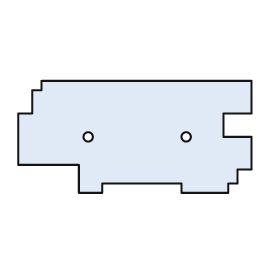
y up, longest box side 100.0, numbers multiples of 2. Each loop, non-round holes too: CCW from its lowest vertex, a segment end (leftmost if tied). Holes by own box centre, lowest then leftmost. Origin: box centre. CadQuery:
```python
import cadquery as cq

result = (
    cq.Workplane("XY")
    .moveTo(-24.0, -24.0)
    .lineTo(-14.0, -24.0)
    .lineTo(-14.0, -20.0)
    .lineTo(20.0, -20.0)
    .lineTo(20.0, -24.0)
    .lineTo(40.0, -24.0)
    .lineTo(40.0, -20.0)
    .lineTo(44.0, -20.0)
    .lineTo(44.0, -14.0)
    .lineTo(50.0, -14.0)
    .lineTo(50.0, 0.0)
    .lineTo(38.0, 0.0)
    .lineTo(38.0, 10.0)
    .lineTo(50.0, 10.0)
    .lineTo(50.0, 24.0)
    .lineTo(-40.0, 24.0)
    .lineTo(-40.0, 20.0)
    .lineTo(-44.0, 20.0)
    .lineTo(-44.0, 10.0)
    .lineTo(-50.0, 10.0)
    .lineTo(-50.0, -12.0)
    .lineTo(-24.0, -12.0)
    .close()
    .moveTo(-20.0, 0.0)
    .circle(2.0)
    .moveTo(22.0, 0.0)
    .circle(2.0)
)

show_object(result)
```